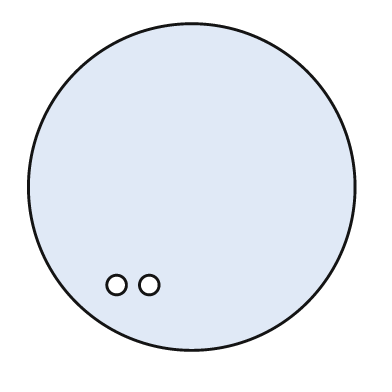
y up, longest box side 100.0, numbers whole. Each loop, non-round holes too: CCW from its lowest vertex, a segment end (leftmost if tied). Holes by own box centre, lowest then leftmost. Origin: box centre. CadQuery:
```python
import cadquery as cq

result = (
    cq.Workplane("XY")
    .moveTo(0.0, 0.0)
    .circle(50.0)
    .moveTo(-23.0, -30.0)
    .circle(3.0)
    .moveTo(-13.0, -30.0)
    .circle(3.0)
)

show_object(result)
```